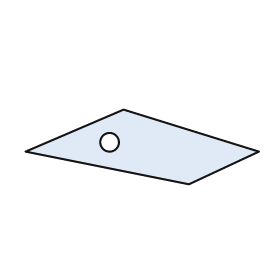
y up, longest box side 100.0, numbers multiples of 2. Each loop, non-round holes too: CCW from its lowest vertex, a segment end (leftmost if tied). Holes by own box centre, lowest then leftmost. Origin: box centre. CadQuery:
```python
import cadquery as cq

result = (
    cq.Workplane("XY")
    .moveTo(20.0, -16.0)
    .lineTo(50.0, -2.0)
    .lineTo(-8.0, 16.0)
    .lineTo(-50.0, -2.0)
    .close()
    .moveTo(-14.0, 2.0)
    .circle(4.0)
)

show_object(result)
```